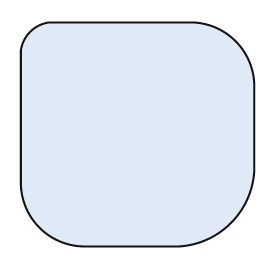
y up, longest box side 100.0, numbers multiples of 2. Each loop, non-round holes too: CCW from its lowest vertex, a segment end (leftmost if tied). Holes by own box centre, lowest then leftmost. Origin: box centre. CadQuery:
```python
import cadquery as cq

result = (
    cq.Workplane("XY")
    .moveTo(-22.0, -48.0)
    .lineTo(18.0, -48.0)
    .threePointArc((40.0, -38.0), (50.0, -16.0))
    .lineTo(50.0, 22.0)
    .threePointArc((42.0, 40.0), (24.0, 48.0))
    .lineTo(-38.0, 48.0)
    .threePointArc((-46.0, 44.0), (-50.0, 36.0))
    .lineTo(-50.0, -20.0)
    .threePointArc((-42.0, -40.0), (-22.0, -48.0))
    .close()
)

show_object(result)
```